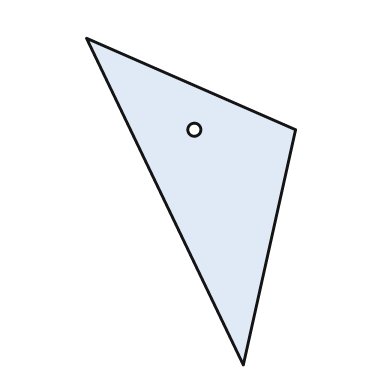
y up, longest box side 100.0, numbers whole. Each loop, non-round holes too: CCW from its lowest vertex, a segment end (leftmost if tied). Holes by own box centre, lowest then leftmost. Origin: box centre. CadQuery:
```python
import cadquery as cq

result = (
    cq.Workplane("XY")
    .moveTo(16.0, -50.0)
    .lineTo(32.0, 22.0)
    .lineTo(-32.0, 50.0)
    .close()
    .moveTo(1.0, 22.0)
    .circle(2.0)
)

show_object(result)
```